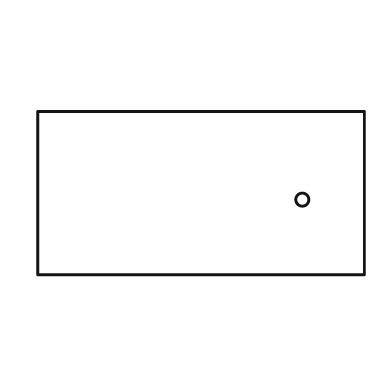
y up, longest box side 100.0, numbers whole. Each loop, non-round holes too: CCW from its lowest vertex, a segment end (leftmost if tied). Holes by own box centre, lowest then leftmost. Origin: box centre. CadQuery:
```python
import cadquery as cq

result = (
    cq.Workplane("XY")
    .moveTo(-50.0, -25.0)
    .lineTo(50.0, -25.0)
    .lineTo(50.0, 25.0)
    .lineTo(-50.0, 25.0)
    .close()
    .moveTo(31.0, -2.0)
    .circle(2.0)
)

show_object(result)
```